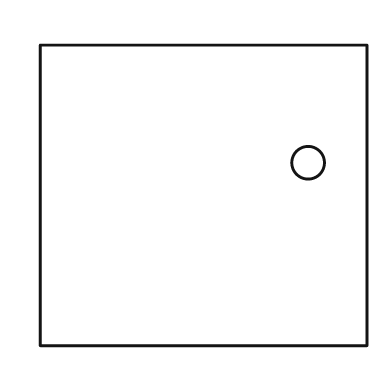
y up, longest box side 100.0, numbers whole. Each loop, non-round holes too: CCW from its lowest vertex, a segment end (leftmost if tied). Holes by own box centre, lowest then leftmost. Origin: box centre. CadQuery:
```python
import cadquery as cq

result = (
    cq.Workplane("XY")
    .moveTo(-50.0, -46.0)
    .lineTo(50.0, -46.0)
    .lineTo(50.0, 46.0)
    .lineTo(-50.0, 46.0)
    .close()
    .moveTo(32.0, 10.0)
    .circle(5.0)
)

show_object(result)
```